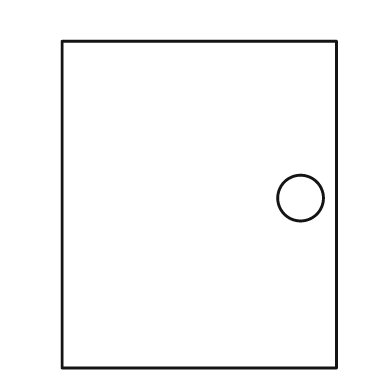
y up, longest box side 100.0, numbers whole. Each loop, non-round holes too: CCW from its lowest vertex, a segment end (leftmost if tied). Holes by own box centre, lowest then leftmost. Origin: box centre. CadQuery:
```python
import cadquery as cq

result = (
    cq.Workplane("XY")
    .moveTo(-42.0, -50.0)
    .lineTo(42.0, -50.0)
    .lineTo(42.0, 50.0)
    .lineTo(-42.0, 50.0)
    .close()
    .moveTo(31.0, 2.0)
    .circle(7.0)
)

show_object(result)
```